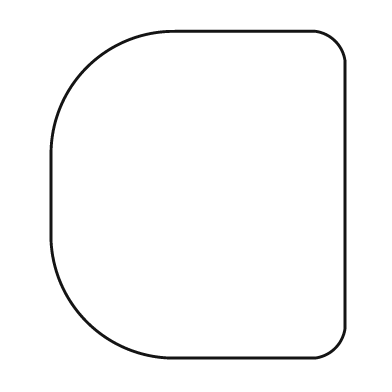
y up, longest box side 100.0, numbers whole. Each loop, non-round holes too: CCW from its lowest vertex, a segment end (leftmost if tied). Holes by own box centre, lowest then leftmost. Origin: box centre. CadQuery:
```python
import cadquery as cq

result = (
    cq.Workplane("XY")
    .moveTo(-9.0, -50.0)
    .lineTo(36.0, -50.0)
    .threePointArc((42.0, -47.0), (45.0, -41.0))
    .lineTo(45.0, 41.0)
    .threePointArc((42.0, 47.0), (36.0, 50.0))
    .lineTo(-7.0, 50.0)
    .threePointArc((-34.0, 39.0), (-45.0, 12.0))
    .lineTo(-45.0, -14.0)
    .threePointArc((-34.0, -39.0), (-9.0, -50.0))
    .close()
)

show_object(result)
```